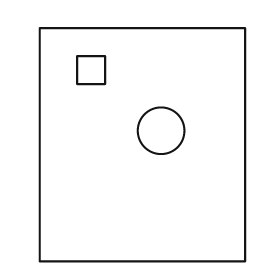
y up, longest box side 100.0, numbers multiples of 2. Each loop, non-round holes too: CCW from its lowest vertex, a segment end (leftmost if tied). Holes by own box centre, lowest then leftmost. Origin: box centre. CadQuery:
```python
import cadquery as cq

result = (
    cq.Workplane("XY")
    .moveTo(-44.0, -50.0)
    .lineTo(44.0, -50.0)
    .lineTo(44.0, 50.0)
    .lineTo(-44.0, 50.0)
    .close()
    .moveTo(8.0, 6.0)
    .circle(10.0)
    .moveTo(-28.0, 26.0)
    .lineTo(-16.0, 26.0)
    .lineTo(-16.0, 38.0)
    .lineTo(-28.0, 38.0)
    .close()
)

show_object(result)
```